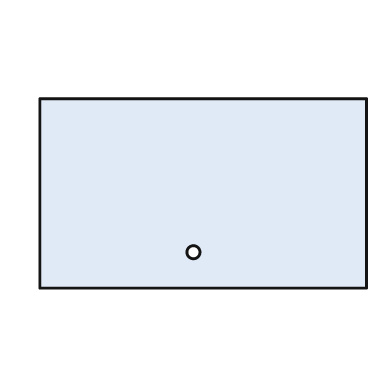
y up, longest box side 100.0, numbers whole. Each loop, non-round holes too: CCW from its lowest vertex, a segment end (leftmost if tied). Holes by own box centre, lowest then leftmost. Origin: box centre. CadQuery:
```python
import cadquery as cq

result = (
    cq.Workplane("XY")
    .moveTo(-50.0, -29.0)
    .lineTo(50.0, -29.0)
    .lineTo(50.0, 29.0)
    .lineTo(-50.0, 29.0)
    .close()
    .moveTo(-3.0, -18.0)
    .circle(2.0)
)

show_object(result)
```